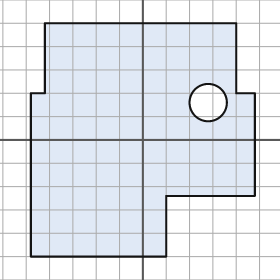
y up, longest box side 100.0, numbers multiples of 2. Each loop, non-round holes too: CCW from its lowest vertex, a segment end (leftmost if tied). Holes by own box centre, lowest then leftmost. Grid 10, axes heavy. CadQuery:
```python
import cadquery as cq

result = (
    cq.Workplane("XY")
    .moveTo(-48.0, -50.0)
    .lineTo(10.0, -50.0)
    .lineTo(10.0, -24.0)
    .lineTo(48.0, -24.0)
    .lineTo(48.0, 20.0)
    .lineTo(40.0, 20.0)
    .lineTo(40.0, 50.0)
    .lineTo(-42.0, 50.0)
    .lineTo(-42.0, 20.0)
    .lineTo(-48.0, 20.0)
    .close()
    .moveTo(28.0, 16.0)
    .circle(8.0)
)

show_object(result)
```